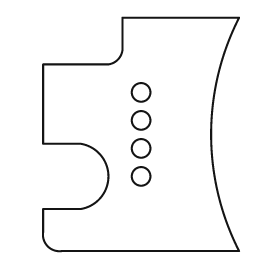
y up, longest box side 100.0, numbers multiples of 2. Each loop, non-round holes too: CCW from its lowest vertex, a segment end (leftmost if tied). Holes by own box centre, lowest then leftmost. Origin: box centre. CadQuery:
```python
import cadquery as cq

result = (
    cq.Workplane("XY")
    .moveTo(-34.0, -50.0)
    .lineTo(42.0, -50.0)
    .threePointArc((30.0, 0.0), (42.0, 50.0))
    .lineTo(-8.0, 50.0)
    .lineTo(-8.0, 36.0)
    .threePointArc((-10.0, 32.0), (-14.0, 30.0))
    .lineTo(-42.0, 30.0)
    .lineTo(-42.0, -4.0)
    .lineTo(-26.0, -4.0)
    .threePointArc((-14.0, -18.0), (-26.0, -32.0))
    .lineTo(-42.0, -32.0)
    .lineTo(-42.0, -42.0)
    .threePointArc((-40.0, -48.0), (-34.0, -50.0))
    .close()
    .moveTo(0.0, -18.0)
    .circle(4.0)
    .moveTo(0.0, -6.0)
    .circle(4.0)
    .moveTo(0.0, 6.0)
    .circle(4.0)
    .moveTo(0.0, 18.0)
    .circle(4.0)
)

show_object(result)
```